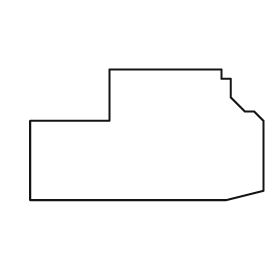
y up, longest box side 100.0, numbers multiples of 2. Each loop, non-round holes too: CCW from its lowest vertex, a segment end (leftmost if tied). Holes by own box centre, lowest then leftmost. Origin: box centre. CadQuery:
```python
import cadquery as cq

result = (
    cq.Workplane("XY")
    .moveTo(-50.0, -28.0)
    .lineTo(34.0, -28.0)
    .lineTo(50.0, -24.0)
    .lineTo(50.0, 6.0)
    .lineTo(46.0, 10.0)
    .lineTo(42.0, 10.0)
    .lineTo(36.0, 16.0)
    .lineTo(36.0, 24.0)
    .lineTo(32.0, 24.0)
    .lineTo(32.0, 28.0)
    .lineTo(-16.0, 28.0)
    .lineTo(-16.0, 6.0)
    .lineTo(-50.0, 6.0)
    .close()
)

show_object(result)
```